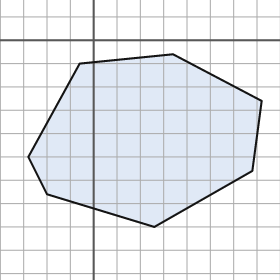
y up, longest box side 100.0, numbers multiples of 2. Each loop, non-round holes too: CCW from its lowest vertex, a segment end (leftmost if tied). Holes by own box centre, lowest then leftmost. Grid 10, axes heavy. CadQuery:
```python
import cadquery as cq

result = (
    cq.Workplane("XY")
    .moveTo(26.0, -80.0)
    .lineTo(68.0, -56.0)
    .lineTo(72.0, -26.0)
    .lineTo(34.0, -6.0)
    .lineTo(-6.0, -10.0)
    .lineTo(-28.0, -50.0)
    .lineTo(-20.0, -66.0)
    .close()
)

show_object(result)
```